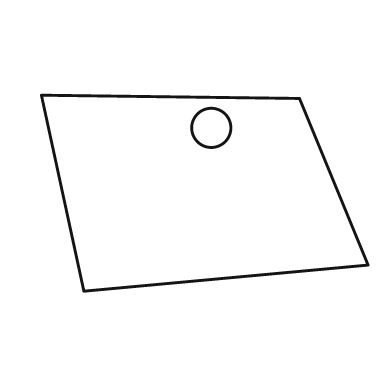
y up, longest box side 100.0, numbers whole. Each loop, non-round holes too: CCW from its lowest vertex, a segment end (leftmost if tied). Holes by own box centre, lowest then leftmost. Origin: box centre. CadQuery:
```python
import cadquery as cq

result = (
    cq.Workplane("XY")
    .moveTo(-37.0, -30.0)
    .lineTo(50.0, -22.0)
    .lineTo(29.0, 29.0)
    .lineTo(-50.0, 30.0)
    .close()
    .moveTo(2.0, 20.0)
    .circle(6.0)
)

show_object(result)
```